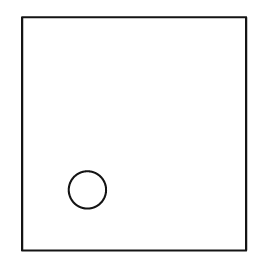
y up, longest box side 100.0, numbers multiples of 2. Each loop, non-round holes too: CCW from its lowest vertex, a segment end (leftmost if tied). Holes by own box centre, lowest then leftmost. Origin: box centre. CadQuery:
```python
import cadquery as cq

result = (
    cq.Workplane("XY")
    .moveTo(-48.0, -50.0)
    .lineTo(48.0, -50.0)
    .lineTo(48.0, 50.0)
    .lineTo(-48.0, 50.0)
    .close()
    .moveTo(-20.0, -24.0)
    .circle(8.0)
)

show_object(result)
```